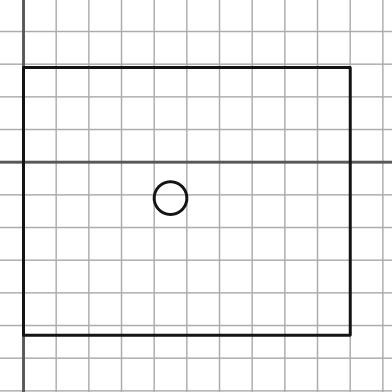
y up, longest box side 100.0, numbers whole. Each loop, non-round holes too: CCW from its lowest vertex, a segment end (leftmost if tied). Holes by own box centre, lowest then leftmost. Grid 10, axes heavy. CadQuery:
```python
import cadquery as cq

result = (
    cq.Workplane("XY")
    .moveTo(0.0, -53.0)
    .lineTo(100.0, -53.0)
    .lineTo(100.0, 29.0)
    .lineTo(0.0, 29.0)
    .close()
    .moveTo(45.0, -11.0)
    .circle(5.0)
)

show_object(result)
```